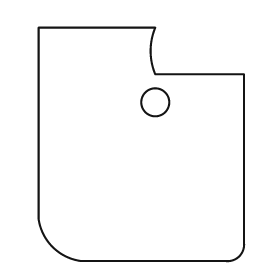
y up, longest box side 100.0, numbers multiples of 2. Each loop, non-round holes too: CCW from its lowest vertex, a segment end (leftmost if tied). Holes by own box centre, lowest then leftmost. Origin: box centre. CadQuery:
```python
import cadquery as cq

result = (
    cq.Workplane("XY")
    .moveTo(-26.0, -50.0)
    .lineTo(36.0, -50.0)
    .threePointArc((42.0, -48.0), (44.0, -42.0))
    .lineTo(44.0, 30.0)
    .lineTo(6.0, 30.0)
    .threePointArc((4.0, 40.0), (6.0, 50.0))
    .lineTo(-44.0, 50.0)
    .lineTo(-44.0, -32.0)
    .threePointArc((-38.0, -44.0), (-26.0, -50.0))
    .close()
    .moveTo(6.0, 18.0)
    .circle(6.0)
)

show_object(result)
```